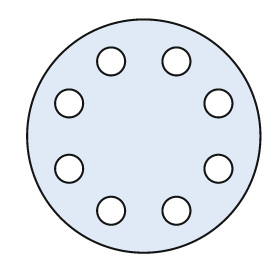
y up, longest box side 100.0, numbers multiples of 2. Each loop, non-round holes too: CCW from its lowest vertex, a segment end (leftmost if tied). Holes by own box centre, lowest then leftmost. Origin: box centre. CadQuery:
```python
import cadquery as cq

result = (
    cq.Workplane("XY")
    .moveTo(0.0, 0.0)
    .circle(50.0)
    .moveTo(-14.0, -32.0)
    .circle(6.0)
    .moveTo(14.0, -32.0)
    .circle(6.0)
    .moveTo(-32.0, -14.0)
    .circle(6.0)
    .moveTo(32.0, -14.0)
    .circle(6.0)
    .moveTo(-32.0, 14.0)
    .circle(6.0)
    .moveTo(32.0, 14.0)
    .circle(6.0)
    .moveTo(-14.0, 32.0)
    .circle(6.0)
    .moveTo(14.0, 32.0)
    .circle(6.0)
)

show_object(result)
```